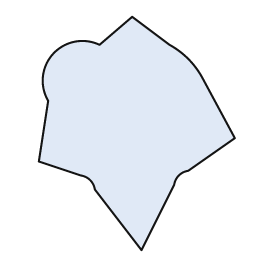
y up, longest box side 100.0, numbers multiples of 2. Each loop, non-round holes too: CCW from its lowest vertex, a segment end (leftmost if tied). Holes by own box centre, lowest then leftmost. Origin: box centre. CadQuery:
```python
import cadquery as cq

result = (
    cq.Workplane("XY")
    .moveTo(2.0, -50.0)
    .lineTo(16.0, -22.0)
    .threePointArc((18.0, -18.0), (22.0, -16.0))
    .lineTo(42.0, -2.0)
    .lineTo(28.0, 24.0)
    .threePointArc((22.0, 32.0), (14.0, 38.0))
    .lineTo(-2.0, 50.0)
    .lineTo(-16.0, 38.0)
    .threePointArc((-36.0, 34.0), (-38.0, 14.0))
    .lineTo(-42.0, -12.0)
    .lineTo(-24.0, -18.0)
    .threePointArc((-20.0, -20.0), (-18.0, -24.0))
    .close()
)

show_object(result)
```